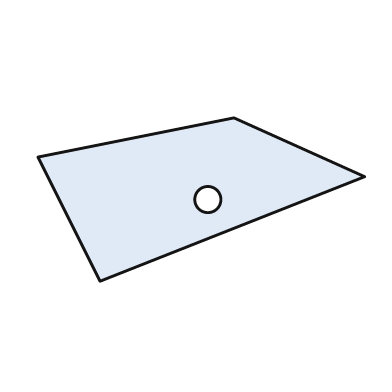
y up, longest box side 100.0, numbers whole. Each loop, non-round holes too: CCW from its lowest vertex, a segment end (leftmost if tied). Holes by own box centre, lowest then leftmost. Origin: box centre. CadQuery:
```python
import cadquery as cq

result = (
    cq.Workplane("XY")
    .moveTo(-31.0, -25.0)
    .lineTo(50.0, 7.0)
    .lineTo(10.0, 25.0)
    .lineTo(-50.0, 13.0)
    .close()
    .moveTo(2.0, 0.0)
    .circle(4.0)
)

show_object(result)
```